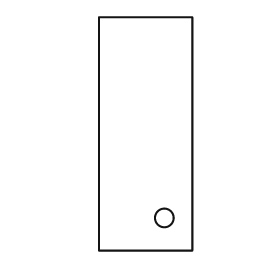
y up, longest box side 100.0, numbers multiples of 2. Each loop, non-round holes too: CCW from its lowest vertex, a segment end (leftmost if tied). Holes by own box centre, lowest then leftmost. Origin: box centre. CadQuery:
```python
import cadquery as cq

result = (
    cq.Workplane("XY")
    .moveTo(-20.0, -50.0)
    .lineTo(20.0, -50.0)
    .lineTo(20.0, 50.0)
    .lineTo(-20.0, 50.0)
    .close()
    .moveTo(8.0, -36.0)
    .circle(4.0)
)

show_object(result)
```